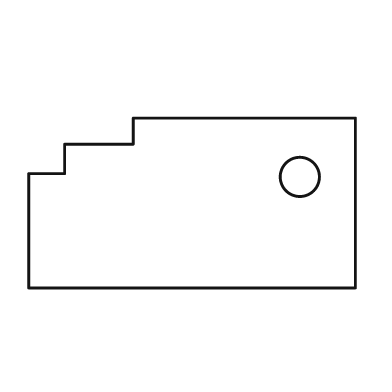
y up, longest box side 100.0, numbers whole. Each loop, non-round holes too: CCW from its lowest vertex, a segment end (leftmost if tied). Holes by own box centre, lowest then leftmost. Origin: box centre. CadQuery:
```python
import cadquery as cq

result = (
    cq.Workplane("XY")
    .moveTo(-50.0, -26.0)
    .lineTo(50.0, -26.0)
    .lineTo(50.0, 26.0)
    .lineTo(-18.0, 26.0)
    .lineTo(-18.0, 18.0)
    .lineTo(-39.0, 18.0)
    .lineTo(-39.0, 9.0)
    .lineTo(-50.0, 9.0)
    .close()
    .moveTo(33.0, 8.0)
    .circle(6.0)
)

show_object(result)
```